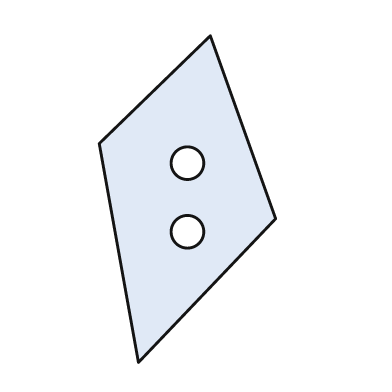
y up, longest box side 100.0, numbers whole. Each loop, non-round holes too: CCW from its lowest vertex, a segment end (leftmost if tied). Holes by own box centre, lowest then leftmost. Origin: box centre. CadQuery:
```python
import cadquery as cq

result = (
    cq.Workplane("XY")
    .moveTo(-15.0, -50.0)
    .lineTo(27.0, -6.0)
    .lineTo(7.0, 50.0)
    .lineTo(-27.0, 17.0)
    .close()
    .moveTo(0.0, -10.0)
    .circle(5.0)
    .moveTo(0.0, 11.0)
    .circle(5.0)
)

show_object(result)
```